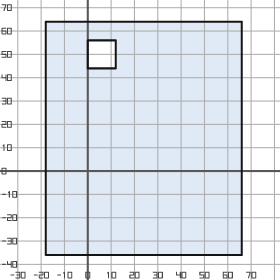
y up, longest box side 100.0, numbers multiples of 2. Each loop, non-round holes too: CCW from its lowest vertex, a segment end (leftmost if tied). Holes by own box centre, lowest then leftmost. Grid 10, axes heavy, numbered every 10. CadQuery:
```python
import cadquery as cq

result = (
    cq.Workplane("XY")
    .moveTo(-18.0, -36.0)
    .lineTo(66.0, -36.0)
    .lineTo(66.0, 64.0)
    .lineTo(-18.0, 64.0)
    .close()
    .moveTo(0.0, 44.0)
    .lineTo(12.0, 44.0)
    .lineTo(12.0, 56.0)
    .lineTo(0.0, 56.0)
    .close()
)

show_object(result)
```